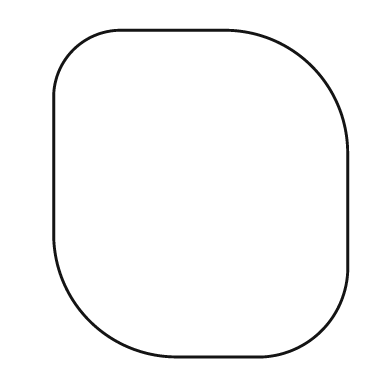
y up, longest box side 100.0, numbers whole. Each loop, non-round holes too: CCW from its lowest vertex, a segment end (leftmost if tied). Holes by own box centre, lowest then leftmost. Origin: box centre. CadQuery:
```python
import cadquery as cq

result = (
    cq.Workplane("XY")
    .moveTo(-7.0, -50.0)
    .lineTo(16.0, -50.0)
    .threePointArc((37.0, -42.0), (45.0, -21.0))
    .lineTo(45.0, 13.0)
    .threePointArc((34.0, 39.0), (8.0, 50.0))
    .lineTo(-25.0, 50.0)
    .threePointArc((-39.0, 44.0), (-45.0, 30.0))
    .lineTo(-45.0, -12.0)
    .threePointArc((-34.0, -39.0), (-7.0, -50.0))
    .close()
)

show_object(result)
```